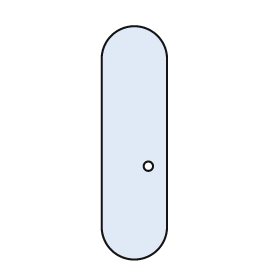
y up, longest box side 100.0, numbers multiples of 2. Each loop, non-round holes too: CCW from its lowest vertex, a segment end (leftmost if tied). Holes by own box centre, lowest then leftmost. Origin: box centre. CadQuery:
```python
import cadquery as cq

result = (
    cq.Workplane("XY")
    .moveTo(-14.0, -36.0)
    .threePointArc((0.0, -50.0), (14.0, -36.0))
    .lineTo(14.0, 36.0)
    .threePointArc((0.0, 50.0), (-14.0, 36.0))
    .close()
    .moveTo(6.0, -10.0)
    .circle(2.0)
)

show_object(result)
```